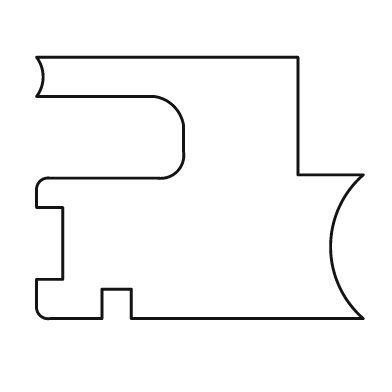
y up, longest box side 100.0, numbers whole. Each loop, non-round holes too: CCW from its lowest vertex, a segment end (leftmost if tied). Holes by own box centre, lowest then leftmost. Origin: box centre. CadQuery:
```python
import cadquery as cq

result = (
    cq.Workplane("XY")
    .moveTo(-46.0, -40.0)
    .lineTo(-30.0, -40.0)
    .lineTo(-30.0, -31.0)
    .lineTo(-21.0, -31.0)
    .lineTo(-21.0, -40.0)
    .lineTo(50.0, -40.0)
    .threePointArc((40.0, -18.0), (50.0, 4.0))
    .lineTo(30.0, 4.0)
    .lineTo(30.0, 40.0)
    .lineTo(-50.0, 40.0)
    .threePointArc((-48.0, 34.0), (-50.0, 28.0))
    .lineTo(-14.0, 28.0)
    .threePointArc((-8.0, 25.0), (-5.0, 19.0))
    .lineTo(-5.0, 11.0)
    .threePointArc((-7.0, 5.0), (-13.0, 3.0))
    .lineTo(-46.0, 3.0)
    .threePointArc((-49.0, 2.0), (-50.0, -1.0))
    .lineTo(-50.0, -6.0)
    .lineTo(-42.0, -6.0)
    .lineTo(-42.0, -28.0)
    .lineTo(-50.0, -28.0)
    .lineTo(-50.0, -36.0)
    .threePointArc((-49.0, -39.0), (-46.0, -40.0))
    .close()
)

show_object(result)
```